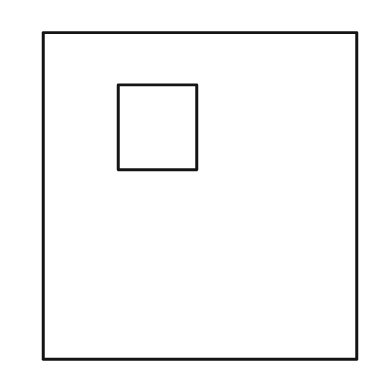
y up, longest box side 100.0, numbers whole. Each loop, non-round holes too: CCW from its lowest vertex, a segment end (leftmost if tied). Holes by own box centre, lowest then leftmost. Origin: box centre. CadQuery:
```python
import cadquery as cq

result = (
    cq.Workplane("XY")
    .moveTo(-48.0, -50.0)
    .lineTo(48.0, -50.0)
    .lineTo(48.0, 50.0)
    .lineTo(-48.0, 50.0)
    .close()
    .moveTo(-25.0, 8.0)
    .lineTo(-1.0, 8.0)
    .lineTo(-1.0, 34.0)
    .lineTo(-25.0, 34.0)
    .close()
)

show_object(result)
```